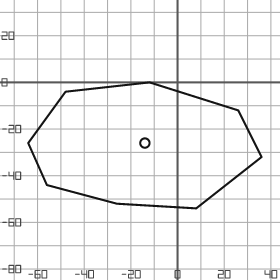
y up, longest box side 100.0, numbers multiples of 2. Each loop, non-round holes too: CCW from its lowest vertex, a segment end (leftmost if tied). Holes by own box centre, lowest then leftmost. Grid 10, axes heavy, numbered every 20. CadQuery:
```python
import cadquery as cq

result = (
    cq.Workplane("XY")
    .moveTo(8.0, -54.0)
    .lineTo(36.0, -32.0)
    .lineTo(26.0, -12.0)
    .lineTo(-12.0, 0.0)
    .lineTo(-48.0, -4.0)
    .lineTo(-64.0, -26.0)
    .lineTo(-56.0, -44.0)
    .lineTo(-26.0, -52.0)
    .close()
    .moveTo(-14.0, -26.0)
    .circle(2.0)
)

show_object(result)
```